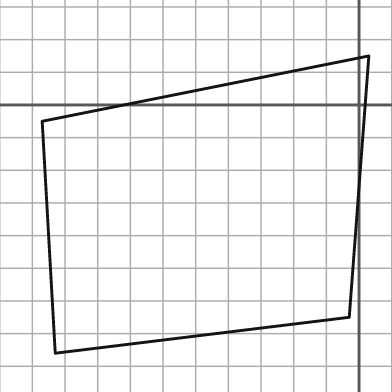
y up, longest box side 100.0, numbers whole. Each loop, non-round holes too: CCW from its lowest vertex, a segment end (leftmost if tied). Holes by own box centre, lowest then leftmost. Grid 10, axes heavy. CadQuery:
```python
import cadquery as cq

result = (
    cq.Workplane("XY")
    .moveTo(-93.0, -76.0)
    .lineTo(-3.0, -65.0)
    .lineTo(3.0, 15.0)
    .lineTo(-97.0, -5.0)
    .close()
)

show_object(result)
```